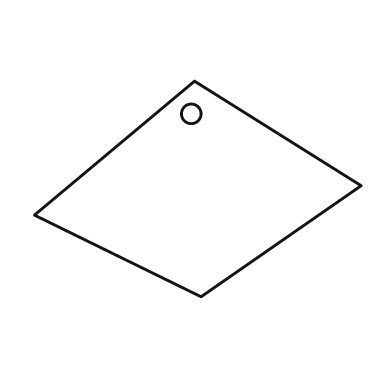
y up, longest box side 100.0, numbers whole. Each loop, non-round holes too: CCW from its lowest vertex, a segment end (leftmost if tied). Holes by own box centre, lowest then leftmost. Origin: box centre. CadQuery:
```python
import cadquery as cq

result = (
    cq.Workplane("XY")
    .moveTo(1.0, -33.0)
    .lineTo(50.0, 1.0)
    .lineTo(-1.0, 33.0)
    .lineTo(-50.0, -8.0)
    .close()
    .moveTo(-2.0, 23.0)
    .circle(3.0)
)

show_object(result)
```